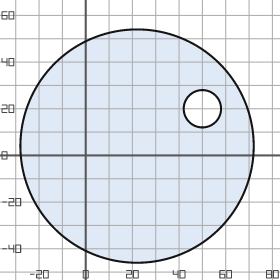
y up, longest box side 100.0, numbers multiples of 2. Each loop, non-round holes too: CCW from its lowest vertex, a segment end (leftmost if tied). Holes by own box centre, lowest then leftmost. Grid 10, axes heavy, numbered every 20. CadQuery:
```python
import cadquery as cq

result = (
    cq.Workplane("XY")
    .moveTo(22.0, 4.0)
    .circle(50.0)
    .moveTo(50.0, 20.0)
    .circle(8.0)
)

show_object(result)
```